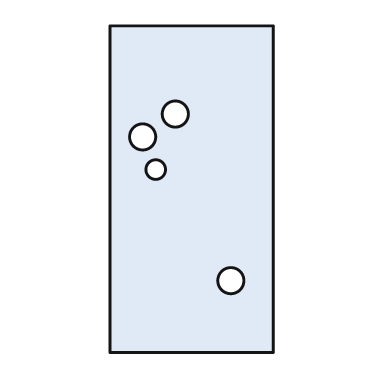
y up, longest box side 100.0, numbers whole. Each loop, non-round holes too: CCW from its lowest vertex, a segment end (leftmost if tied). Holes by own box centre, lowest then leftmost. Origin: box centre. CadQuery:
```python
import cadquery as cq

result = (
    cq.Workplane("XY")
    .moveTo(-25.0, -50.0)
    .lineTo(25.0, -50.0)
    .lineTo(25.0, 50.0)
    .lineTo(-25.0, 50.0)
    .close()
    .moveTo(12.0, -28.0)
    .circle(4.0)
    .moveTo(-11.0, 6.0)
    .circle(3.0)
    .moveTo(-15.0, 16.0)
    .circle(4.0)
    .moveTo(-5.0, 23.0)
    .circle(4.0)
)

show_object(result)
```